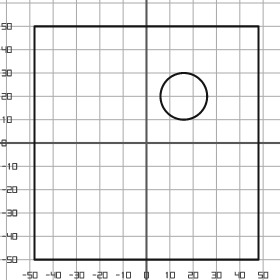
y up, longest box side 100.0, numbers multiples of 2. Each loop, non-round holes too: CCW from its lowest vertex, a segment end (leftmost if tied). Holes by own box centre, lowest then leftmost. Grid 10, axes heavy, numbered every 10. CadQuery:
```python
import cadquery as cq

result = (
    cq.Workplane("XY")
    .moveTo(-48.0, -50.0)
    .lineTo(48.0, -50.0)
    .lineTo(48.0, 50.0)
    .lineTo(-48.0, 50.0)
    .close()
    .moveTo(16.0, 20.0)
    .circle(10.0)
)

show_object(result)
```